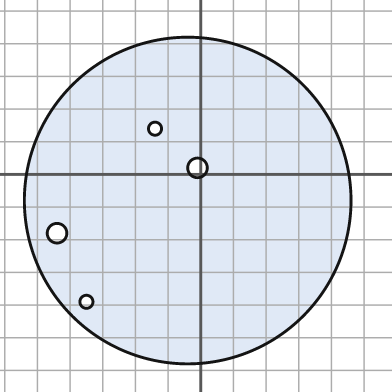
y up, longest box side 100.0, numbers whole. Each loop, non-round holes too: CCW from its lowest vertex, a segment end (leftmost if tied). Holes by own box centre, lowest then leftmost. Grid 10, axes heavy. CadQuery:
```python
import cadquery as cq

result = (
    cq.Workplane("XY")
    .moveTo(-4.0, -8.0)
    .circle(50.0)
    .moveTo(-35.0, -39.0)
    .circle(2.0)
    .moveTo(-44.0, -18.0)
    .circle(3.0)
    .moveTo(-1.0, 2.0)
    .circle(3.0)
    .moveTo(-14.0, 14.0)
    .circle(2.0)
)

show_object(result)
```